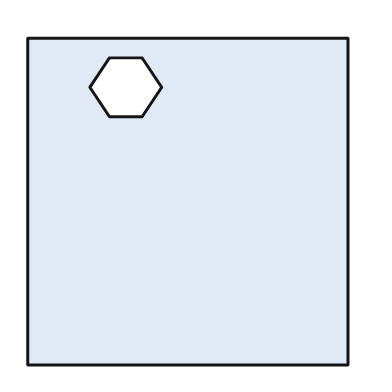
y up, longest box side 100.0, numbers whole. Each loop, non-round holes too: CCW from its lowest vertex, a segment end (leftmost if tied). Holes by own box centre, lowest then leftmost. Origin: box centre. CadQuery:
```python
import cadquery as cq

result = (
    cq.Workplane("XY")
    .moveTo(-49.0, -50.0)
    .lineTo(49.0, -50.0)
    .lineTo(49.0, 50.0)
    .lineTo(-49.0, 50.0)
    .close()
    .moveTo(-24.0, 26.0)
    .lineTo(-14.0, 26.0)
    .lineTo(-8.0, 35.0)
    .lineTo(-14.0, 44.0)
    .lineTo(-24.0, 44.0)
    .lineTo(-30.0, 35.0)
    .close()
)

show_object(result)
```